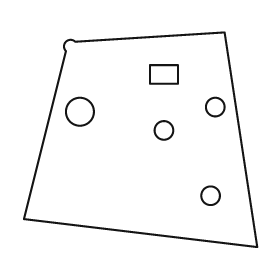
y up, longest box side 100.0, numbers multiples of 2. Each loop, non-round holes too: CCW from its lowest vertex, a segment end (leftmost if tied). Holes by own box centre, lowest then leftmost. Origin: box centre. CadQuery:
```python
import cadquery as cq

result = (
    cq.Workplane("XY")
    .moveTo(50.0, -46.0)
    .lineTo(36.0, 46.0)
    .lineTo(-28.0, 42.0)
    .threePointArc((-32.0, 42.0), (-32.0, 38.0))
    .lineTo(-50.0, -34.0)
    .close()
    .moveTo(30.0, -24.0)
    .circle(4.0)
    .moveTo(10.0, 4.0)
    .circle(4.0)
    .moveTo(-26.0, 12.0)
    .circle(6.0)
    .moveTo(32.0, 14.0)
    .circle(4.0)
    .moveTo(4.0, 24.0)
    .lineTo(16.0, 24.0)
    .lineTo(16.0, 32.0)
    .lineTo(4.0, 32.0)
    .close()
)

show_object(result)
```